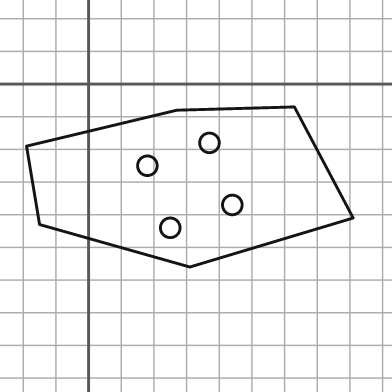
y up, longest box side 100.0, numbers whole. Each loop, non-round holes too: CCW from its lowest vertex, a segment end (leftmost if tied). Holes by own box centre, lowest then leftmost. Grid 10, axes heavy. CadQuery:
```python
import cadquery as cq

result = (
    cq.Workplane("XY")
    .moveTo(31.0, -56.0)
    .lineTo(81.0, -41.0)
    .lineTo(63.0, -7.0)
    .lineTo(27.0, -8.0)
    .lineTo(-19.0, -19.0)
    .lineTo(-15.0, -43.0)
    .close()
    .moveTo(25.0, -44.0)
    .circle(3.0)
    .moveTo(44.0, -37.0)
    .circle(3.0)
    .moveTo(18.0, -25.0)
    .circle(3.0)
    .moveTo(37.0, -18.0)
    .circle(3.0)
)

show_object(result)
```